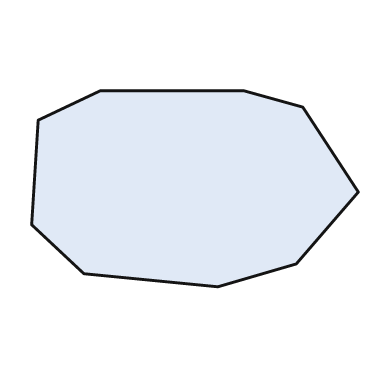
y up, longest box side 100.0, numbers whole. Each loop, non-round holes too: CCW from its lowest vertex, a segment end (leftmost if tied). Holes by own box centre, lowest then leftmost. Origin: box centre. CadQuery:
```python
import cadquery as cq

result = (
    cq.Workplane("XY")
    .moveTo(7.0, -30.0)
    .lineTo(31.0, -23.0)
    .lineTo(50.0, -1.0)
    .lineTo(33.0, 25.0)
    .lineTo(15.0, 30.0)
    .lineTo(-29.0, 30.0)
    .lineTo(-48.0, 21.0)
    .lineTo(-50.0, -11.0)
    .lineTo(-34.0, -26.0)
    .close()
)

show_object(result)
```